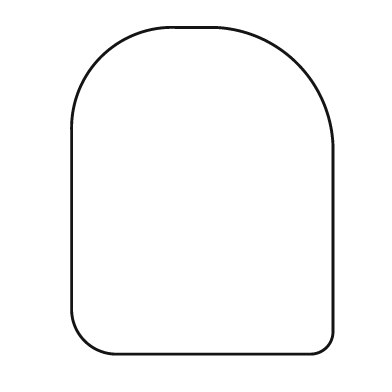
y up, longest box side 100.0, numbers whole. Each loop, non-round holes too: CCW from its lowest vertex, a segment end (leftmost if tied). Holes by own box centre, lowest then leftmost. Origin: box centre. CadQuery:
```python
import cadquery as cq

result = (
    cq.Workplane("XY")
    .moveTo(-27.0, -50.0)
    .lineTo(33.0, -50.0)
    .threePointArc((38.0, -48.0), (40.0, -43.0))
    .lineTo(40.0, 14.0)
    .threePointArc((29.0, 39.0), (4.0, 50.0))
    .lineTo(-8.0, 50.0)
    .threePointArc((-31.0, 41.0), (-40.0, 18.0))
    .lineTo(-40.0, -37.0)
    .threePointArc((-36.0, -46.0), (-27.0, -50.0))
    .close()
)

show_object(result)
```